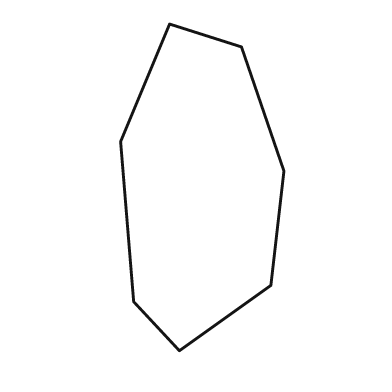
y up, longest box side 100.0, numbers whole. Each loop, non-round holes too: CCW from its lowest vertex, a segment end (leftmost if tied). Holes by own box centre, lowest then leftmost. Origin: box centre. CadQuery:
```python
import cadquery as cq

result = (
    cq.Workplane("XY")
    .moveTo(-7.0, -50.0)
    .lineTo(21.0, -30.0)
    .lineTo(25.0, 5.0)
    .lineTo(12.0, 43.0)
    .lineTo(-10.0, 50.0)
    .lineTo(-25.0, 14.0)
    .lineTo(-21.0, -35.0)
    .close()
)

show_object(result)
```